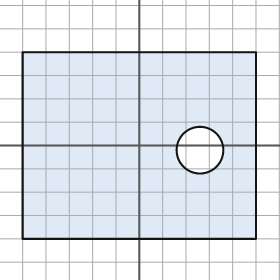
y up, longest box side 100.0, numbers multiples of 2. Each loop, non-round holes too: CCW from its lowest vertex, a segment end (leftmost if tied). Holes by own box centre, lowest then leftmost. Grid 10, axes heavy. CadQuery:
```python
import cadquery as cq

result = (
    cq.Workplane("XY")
    .moveTo(-50.0, -40.0)
    .lineTo(50.0, -40.0)
    .lineTo(50.0, 40.0)
    .lineTo(-50.0, 40.0)
    .close()
    .moveTo(26.0, -2.0)
    .circle(10.0)
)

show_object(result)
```